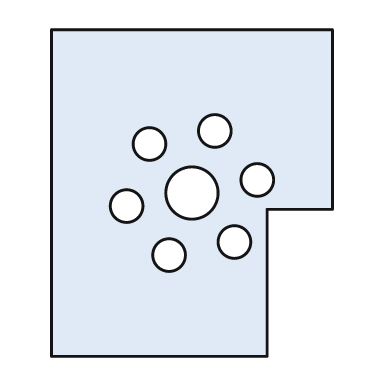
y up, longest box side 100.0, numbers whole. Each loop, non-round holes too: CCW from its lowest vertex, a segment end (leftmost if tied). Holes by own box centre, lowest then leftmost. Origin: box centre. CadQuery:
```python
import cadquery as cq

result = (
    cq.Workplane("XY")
    .moveTo(-43.0, -50.0)
    .lineTo(23.0, -50.0)
    .lineTo(23.0, -5.0)
    .lineTo(43.0, -5.0)
    .lineTo(43.0, 50.0)
    .lineTo(-43.0, 50.0)
    .close()
    .moveTo(-7.0, -19.0)
    .circle(5.0)
    .moveTo(13.0, -15.0)
    .circle(5.0)
    .moveTo(-20.0, -4.0)
    .circle(5.0)
    .moveTo(0.0, 0.0)
    .circle(8.0)
    .moveTo(20.0, 4.0)
    .circle(5.0)
    .moveTo(-13.0, 15.0)
    .circle(5.0)
    .moveTo(7.0, 19.0)
    .circle(5.0)
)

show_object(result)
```